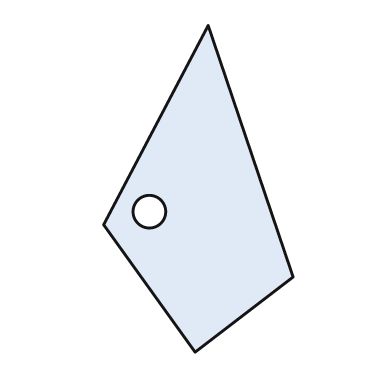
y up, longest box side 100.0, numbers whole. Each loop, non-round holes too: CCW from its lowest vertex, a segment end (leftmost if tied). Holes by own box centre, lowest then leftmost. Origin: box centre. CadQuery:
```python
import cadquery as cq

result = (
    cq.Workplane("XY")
    .moveTo(-1.0, -50.0)
    .lineTo(29.0, -27.0)
    .lineTo(3.0, 50.0)
    .lineTo(-29.0, -11.0)
    .close()
    .moveTo(-15.0, -7.0)
    .circle(5.0)
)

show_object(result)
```